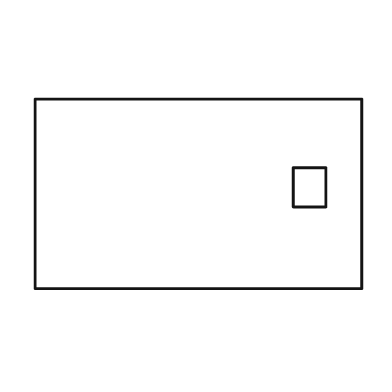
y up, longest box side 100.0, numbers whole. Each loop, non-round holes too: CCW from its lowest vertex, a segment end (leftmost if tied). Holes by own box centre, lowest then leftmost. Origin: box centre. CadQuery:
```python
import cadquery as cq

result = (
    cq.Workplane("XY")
    .moveTo(-50.0, -29.0)
    .lineTo(50.0, -29.0)
    .lineTo(50.0, 29.0)
    .lineTo(-50.0, 29.0)
    .close()
    .moveTo(29.0, -4.0)
    .lineTo(39.0, -4.0)
    .lineTo(39.0, 8.0)
    .lineTo(29.0, 8.0)
    .close()
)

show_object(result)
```